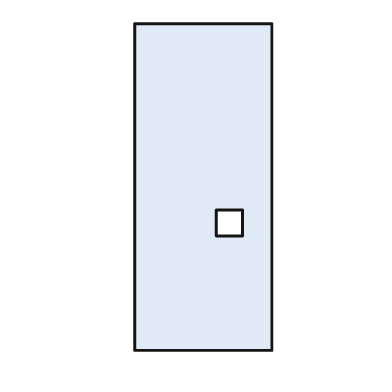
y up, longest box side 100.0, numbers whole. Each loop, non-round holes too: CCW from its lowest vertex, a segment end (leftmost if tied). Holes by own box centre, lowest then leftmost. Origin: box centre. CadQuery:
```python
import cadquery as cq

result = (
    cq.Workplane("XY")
    .moveTo(-21.0, -50.0)
    .lineTo(21.0, -50.0)
    .lineTo(21.0, 50.0)
    .lineTo(-21.0, 50.0)
    .close()
    .moveTo(4.0, -15.0)
    .lineTo(12.0, -15.0)
    .lineTo(12.0, -7.0)
    .lineTo(4.0, -7.0)
    .close()
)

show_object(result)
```